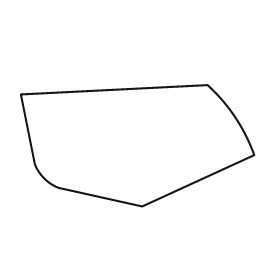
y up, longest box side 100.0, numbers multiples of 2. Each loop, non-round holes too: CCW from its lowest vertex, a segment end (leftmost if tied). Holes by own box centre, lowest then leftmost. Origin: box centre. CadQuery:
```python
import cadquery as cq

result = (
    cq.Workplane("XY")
    .moveTo(2.0, -26.0)
    .lineTo(50.0, -4.0)
    .threePointArc((42.0, 12.0), (30.0, 26.0))
    .lineTo(-50.0, 22.0)
    .lineTo(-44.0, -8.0)
    .threePointArc((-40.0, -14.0), (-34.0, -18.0))
    .close()
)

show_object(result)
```